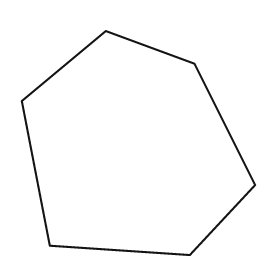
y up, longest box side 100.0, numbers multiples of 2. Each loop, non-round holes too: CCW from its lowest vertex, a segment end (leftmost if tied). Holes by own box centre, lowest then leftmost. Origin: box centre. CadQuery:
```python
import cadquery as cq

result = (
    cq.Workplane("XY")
    .moveTo(22.0, -48.0)
    .lineTo(50.0, -18.0)
    .lineTo(24.0, 34.0)
    .lineTo(-14.0, 48.0)
    .lineTo(-50.0, 18.0)
    .lineTo(-38.0, -44.0)
    .close()
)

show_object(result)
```